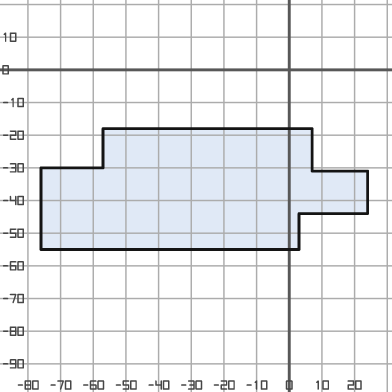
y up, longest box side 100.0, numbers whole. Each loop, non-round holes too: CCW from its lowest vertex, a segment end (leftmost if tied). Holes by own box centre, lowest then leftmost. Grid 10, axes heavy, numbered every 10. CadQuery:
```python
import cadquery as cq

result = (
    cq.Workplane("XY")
    .moveTo(-76.0, -55.0)
    .lineTo(3.0, -55.0)
    .lineTo(3.0, -44.0)
    .lineTo(24.0, -44.0)
    .lineTo(24.0, -31.0)
    .lineTo(7.0, -31.0)
    .lineTo(7.0, -18.0)
    .lineTo(-57.0, -18.0)
    .lineTo(-57.0, -30.0)
    .lineTo(-76.0, -30.0)
    .close()
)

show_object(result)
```